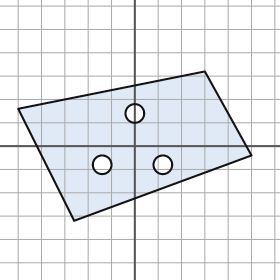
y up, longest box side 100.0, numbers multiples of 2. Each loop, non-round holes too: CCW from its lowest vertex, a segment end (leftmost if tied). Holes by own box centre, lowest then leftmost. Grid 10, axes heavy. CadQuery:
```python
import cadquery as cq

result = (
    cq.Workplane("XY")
    .moveTo(-26.0, -32.0)
    .lineTo(50.0, -4.0)
    .lineTo(30.0, 32.0)
    .lineTo(-50.0, 16.0)
    .close()
    .moveTo(-14.0, -8.0)
    .circle(4.0)
    .moveTo(12.0, -8.0)
    .circle(4.0)
    .moveTo(0.0, 14.0)
    .circle(4.0)
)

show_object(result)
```